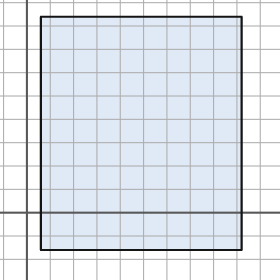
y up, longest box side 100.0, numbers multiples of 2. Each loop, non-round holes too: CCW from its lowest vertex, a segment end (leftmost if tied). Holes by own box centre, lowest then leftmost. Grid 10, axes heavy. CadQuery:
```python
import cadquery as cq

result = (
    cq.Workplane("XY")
    .moveTo(6.0, -16.0)
    .lineTo(92.0, -16.0)
    .lineTo(92.0, 84.0)
    .lineTo(6.0, 84.0)
    .close()
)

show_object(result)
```